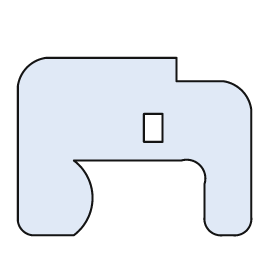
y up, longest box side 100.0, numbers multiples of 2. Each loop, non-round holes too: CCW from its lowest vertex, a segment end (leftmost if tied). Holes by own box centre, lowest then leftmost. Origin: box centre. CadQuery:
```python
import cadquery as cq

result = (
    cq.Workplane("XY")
    .moveTo(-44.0, -38.0)
    .lineTo(-26.0, -38.0)
    .threePointArc((-18.0, -22.0), (-26.0, -6.0))
    .lineTo(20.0, -6.0)
    .threePointArc((28.0, -8.0), (30.0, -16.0))
    .lineTo(30.0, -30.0)
    .threePointArc((32.0, -36.0), (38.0, -38.0))
    .lineTo(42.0, -38.0)
    .threePointArc((48.0, -36.0), (50.0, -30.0))
    .lineTo(50.0, 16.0)
    .threePointArc((46.0, 24.0), (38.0, 28.0))
    .lineTo(18.0, 28.0)
    .lineTo(18.0, 38.0)
    .lineTo(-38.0, 38.0)
    .threePointArc((-46.0, 34.0), (-50.0, 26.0))
    .lineTo(-50.0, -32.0)
    .threePointArc((-48.0, -36.0), (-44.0, -38.0))
    .close()
    .moveTo(4.0, 2.0)
    .lineTo(12.0, 2.0)
    .lineTo(12.0, 14.0)
    .lineTo(4.0, 14.0)
    .close()
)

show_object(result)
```